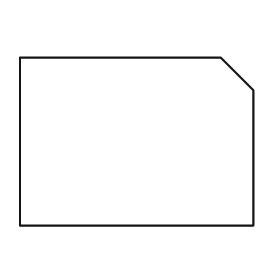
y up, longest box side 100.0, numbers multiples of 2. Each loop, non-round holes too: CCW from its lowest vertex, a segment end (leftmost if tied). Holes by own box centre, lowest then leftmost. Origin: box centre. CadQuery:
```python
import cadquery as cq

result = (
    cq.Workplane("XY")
    .moveTo(-50.0, -36.0)
    .lineTo(50.0, -36.0)
    .lineTo(50.0, 22.0)
    .lineTo(36.0, 36.0)
    .lineTo(-50.0, 36.0)
    .close()
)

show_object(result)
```